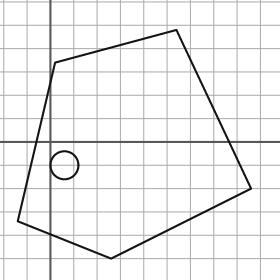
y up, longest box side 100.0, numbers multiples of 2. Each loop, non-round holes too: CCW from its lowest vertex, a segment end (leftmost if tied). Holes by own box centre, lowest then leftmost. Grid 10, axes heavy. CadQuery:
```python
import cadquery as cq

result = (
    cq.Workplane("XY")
    .moveTo(26.0, -50.0)
    .lineTo(86.0, -20.0)
    .lineTo(54.0, 48.0)
    .lineTo(2.0, 34.0)
    .lineTo(-14.0, -34.0)
    .close()
    .moveTo(6.0, -10.0)
    .circle(6.0)
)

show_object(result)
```